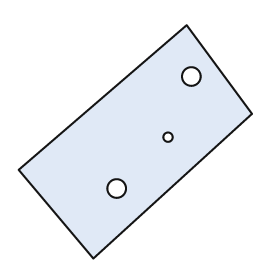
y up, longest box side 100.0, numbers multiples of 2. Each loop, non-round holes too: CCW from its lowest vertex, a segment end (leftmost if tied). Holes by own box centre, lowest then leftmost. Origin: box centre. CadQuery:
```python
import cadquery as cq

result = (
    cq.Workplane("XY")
    .moveTo(-18.0, -50.0)
    .lineTo(50.0, 12.0)
    .lineTo(22.0, 50.0)
    .lineTo(-50.0, -12.0)
    .close()
    .moveTo(-8.0, -20.0)
    .circle(4.0)
    .moveTo(14.0, 2.0)
    .circle(2.0)
    .moveTo(24.0, 28.0)
    .circle(4.0)
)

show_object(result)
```